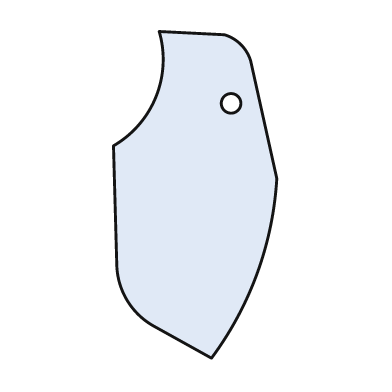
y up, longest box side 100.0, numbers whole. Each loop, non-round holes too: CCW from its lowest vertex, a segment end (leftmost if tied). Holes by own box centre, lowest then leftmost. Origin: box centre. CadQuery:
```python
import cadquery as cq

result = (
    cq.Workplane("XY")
    .moveTo(5.0, -50.0)
    .threePointArc((19.0, -24.0), (25.0, 5.0))
    .lineTo(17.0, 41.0)
    .threePointArc((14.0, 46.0), (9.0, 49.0))
    .lineTo(-11.0, 50.0)
    .threePointArc((-12.0, 30.0), (-25.0, 15.0))
    .lineTo(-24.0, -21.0)
    .threePointArc((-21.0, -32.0), (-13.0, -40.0))
    .close()
    .moveTo(11.0, 28.0)
    .circle(3.0)
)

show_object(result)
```